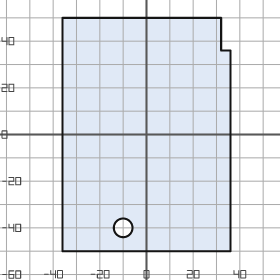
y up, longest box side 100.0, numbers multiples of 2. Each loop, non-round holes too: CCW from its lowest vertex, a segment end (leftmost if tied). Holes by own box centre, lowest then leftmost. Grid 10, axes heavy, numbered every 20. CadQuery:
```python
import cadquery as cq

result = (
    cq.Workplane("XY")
    .moveTo(-36.0, -50.0)
    .lineTo(36.0, -50.0)
    .lineTo(36.0, 36.0)
    .lineTo(32.0, 36.0)
    .lineTo(32.0, 50.0)
    .lineTo(-36.0, 50.0)
    .close()
    .moveTo(-10.0, -40.0)
    .circle(4.0)
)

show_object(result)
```